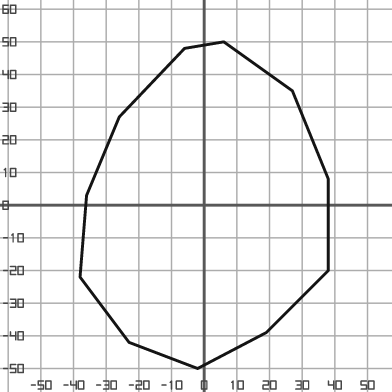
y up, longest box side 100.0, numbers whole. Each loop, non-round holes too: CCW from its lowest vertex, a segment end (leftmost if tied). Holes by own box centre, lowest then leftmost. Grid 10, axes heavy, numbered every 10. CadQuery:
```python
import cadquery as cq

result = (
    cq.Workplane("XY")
    .moveTo(-2.0, -50.0)
    .lineTo(19.0, -39.0)
    .lineTo(38.0, -20.0)
    .lineTo(38.0, 8.0)
    .lineTo(27.0, 35.0)
    .lineTo(6.0, 50.0)
    .lineTo(-6.0, 48.0)
    .lineTo(-26.0, 27.0)
    .lineTo(-36.0, 3.0)
    .lineTo(-38.0, -22.0)
    .lineTo(-23.0, -42.0)
    .close()
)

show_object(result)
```